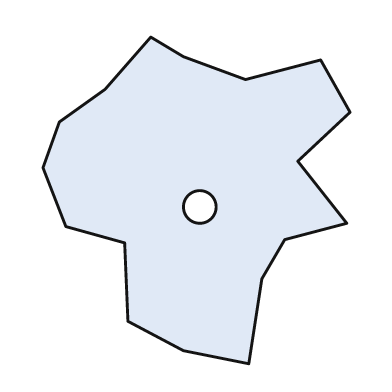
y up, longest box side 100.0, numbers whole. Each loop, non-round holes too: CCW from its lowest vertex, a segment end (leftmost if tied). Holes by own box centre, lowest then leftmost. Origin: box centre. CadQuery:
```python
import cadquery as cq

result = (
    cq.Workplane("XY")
    .moveTo(16.0, -50.0)
    .lineTo(20.0, -24.0)
    .lineTo(27.0, -12.0)
    .lineTo(46.0, -7.0)
    .lineTo(31.0, 12.0)
    .lineTo(47.0, 27.0)
    .lineTo(38.0, 43.0)
    .lineTo(15.0, 37.0)
    .lineTo(-4.0, 44.0)
    .lineTo(-14.0, 50.0)
    .lineTo(-28.0, 34.0)
    .lineTo(-42.0, 24.0)
    .lineTo(-47.0, 10.0)
    .lineTo(-40.0, -8.0)
    .lineTo(-22.0, -13.0)
    .lineTo(-21.0, -37.0)
    .lineTo(-4.0, -46.0)
    .close()
    .moveTo(1.0, -2.0)
    .circle(5.0)
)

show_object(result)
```